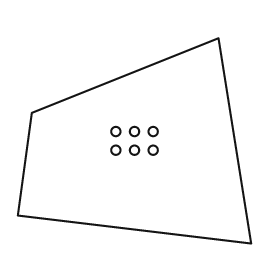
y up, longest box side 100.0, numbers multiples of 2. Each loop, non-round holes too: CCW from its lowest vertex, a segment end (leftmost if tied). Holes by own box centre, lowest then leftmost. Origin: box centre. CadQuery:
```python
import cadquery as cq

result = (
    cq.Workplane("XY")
    .moveTo(50.0, -44.0)
    .lineTo(36.0, 44.0)
    .lineTo(-44.0, 12.0)
    .lineTo(-50.0, -32.0)
    .close()
    .moveTo(-8.0, -4.0)
    .circle(2.0)
    .moveTo(0.0, -4.0)
    .circle(2.0)
    .moveTo(8.0, -4.0)
    .circle(2.0)
    .moveTo(-8.0, 4.0)
    .circle(2.0)
    .moveTo(0.0, 4.0)
    .circle(2.0)
    .moveTo(8.0, 4.0)
    .circle(2.0)
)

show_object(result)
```